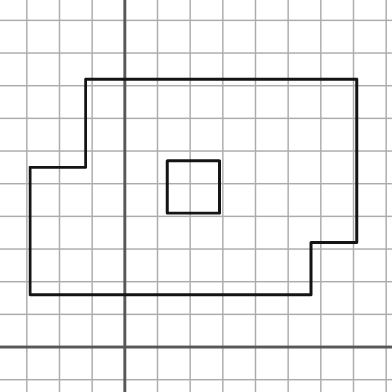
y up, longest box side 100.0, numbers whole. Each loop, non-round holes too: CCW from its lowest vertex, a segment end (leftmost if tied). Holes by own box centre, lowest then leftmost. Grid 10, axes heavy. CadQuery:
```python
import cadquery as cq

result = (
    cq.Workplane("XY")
    .moveTo(-29.0, 16.0)
    .lineTo(57.0, 16.0)
    .lineTo(57.0, 32.0)
    .lineTo(71.0, 32.0)
    .lineTo(71.0, 82.0)
    .lineTo(-12.0, 82.0)
    .lineTo(-12.0, 55.0)
    .lineTo(-29.0, 55.0)
    .close()
    .moveTo(13.0, 41.0)
    .lineTo(29.0, 41.0)
    .lineTo(29.0, 57.0)
    .lineTo(13.0, 57.0)
    .close()
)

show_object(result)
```